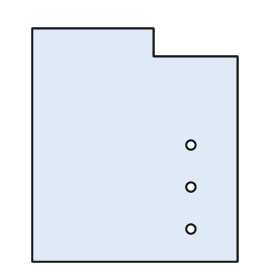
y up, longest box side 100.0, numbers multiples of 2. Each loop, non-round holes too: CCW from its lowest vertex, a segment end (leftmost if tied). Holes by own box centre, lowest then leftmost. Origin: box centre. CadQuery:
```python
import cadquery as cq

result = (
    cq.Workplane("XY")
    .moveTo(-44.0, -50.0)
    .lineTo(44.0, -50.0)
    .lineTo(44.0, 38.0)
    .lineTo(8.0, 38.0)
    .lineTo(8.0, 50.0)
    .lineTo(-44.0, 50.0)
    .close()
    .moveTo(24.0, -36.0)
    .circle(2.0)
    .moveTo(24.0, -18.0)
    .circle(2.0)
    .moveTo(24.0, 0.0)
    .circle(2.0)
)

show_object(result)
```